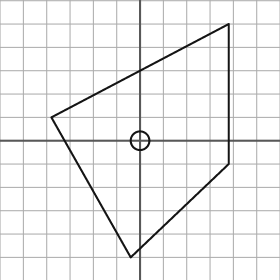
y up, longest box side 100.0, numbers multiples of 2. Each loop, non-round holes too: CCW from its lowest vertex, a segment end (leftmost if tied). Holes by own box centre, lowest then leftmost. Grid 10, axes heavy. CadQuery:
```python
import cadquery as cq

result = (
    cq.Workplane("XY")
    .moveTo(-4.0, -50.0)
    .lineTo(38.0, -10.0)
    .lineTo(38.0, 50.0)
    .lineTo(-38.0, 10.0)
    .close()
    .moveTo(0.0, 0.0)
    .circle(4.0)
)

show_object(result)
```